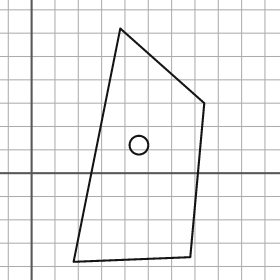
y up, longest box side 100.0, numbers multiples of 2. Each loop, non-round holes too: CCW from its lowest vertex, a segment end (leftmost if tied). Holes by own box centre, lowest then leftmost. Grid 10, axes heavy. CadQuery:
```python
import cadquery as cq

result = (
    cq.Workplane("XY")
    .moveTo(18.0, -38.0)
    .lineTo(68.0, -36.0)
    .lineTo(74.0, 30.0)
    .lineTo(38.0, 62.0)
    .close()
    .moveTo(46.0, 12.0)
    .circle(4.0)
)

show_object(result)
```